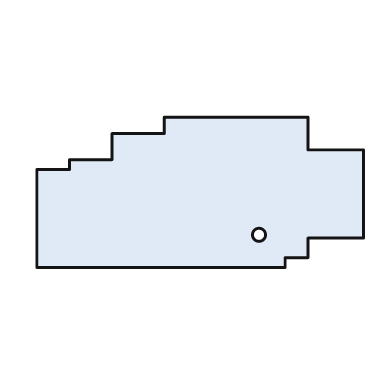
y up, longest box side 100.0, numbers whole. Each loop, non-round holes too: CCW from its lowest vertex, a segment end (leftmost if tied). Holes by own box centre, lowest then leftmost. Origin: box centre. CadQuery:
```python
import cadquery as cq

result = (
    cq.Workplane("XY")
    .moveTo(-50.0, -23.0)
    .lineTo(26.0, -23.0)
    .lineTo(26.0, -20.0)
    .lineTo(33.0, -20.0)
    .lineTo(33.0, -14.0)
    .lineTo(50.0, -14.0)
    .lineTo(50.0, 13.0)
    .lineTo(33.0, 13.0)
    .lineTo(33.0, 23.0)
    .lineTo(-11.0, 23.0)
    .lineTo(-11.0, 18.0)
    .lineTo(-27.0, 18.0)
    .lineTo(-27.0, 10.0)
    .lineTo(-40.0, 10.0)
    .lineTo(-40.0, 7.0)
    .lineTo(-50.0, 7.0)
    .close()
    .moveTo(18.0, -13.0)
    .circle(2.0)
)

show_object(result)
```